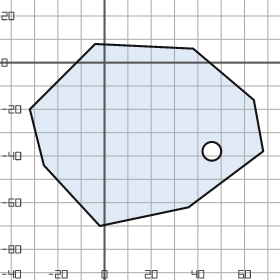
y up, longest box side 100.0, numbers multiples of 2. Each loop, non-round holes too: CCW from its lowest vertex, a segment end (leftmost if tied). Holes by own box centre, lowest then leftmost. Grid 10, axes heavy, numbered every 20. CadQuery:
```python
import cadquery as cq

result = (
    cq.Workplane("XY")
    .moveTo(-2.0, -70.0)
    .lineTo(36.0, -62.0)
    .lineTo(68.0, -38.0)
    .lineTo(64.0, -16.0)
    .lineTo(38.0, 6.0)
    .lineTo(-4.0, 8.0)
    .lineTo(-32.0, -20.0)
    .lineTo(-26.0, -44.0)
    .close()
    .moveTo(46.0, -38.0)
    .circle(4.0)
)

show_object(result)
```